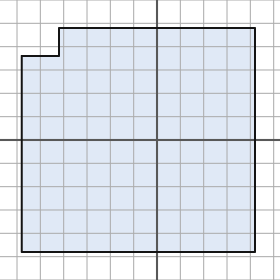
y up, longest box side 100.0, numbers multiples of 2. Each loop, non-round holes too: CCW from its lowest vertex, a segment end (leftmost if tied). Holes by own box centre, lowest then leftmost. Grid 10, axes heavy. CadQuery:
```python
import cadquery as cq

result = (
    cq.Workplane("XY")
    .moveTo(-58.0, -48.0)
    .lineTo(42.0, -48.0)
    .lineTo(42.0, 48.0)
    .lineTo(-42.0, 48.0)
    .lineTo(-42.0, 36.0)
    .lineTo(-58.0, 36.0)
    .close()
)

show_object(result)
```